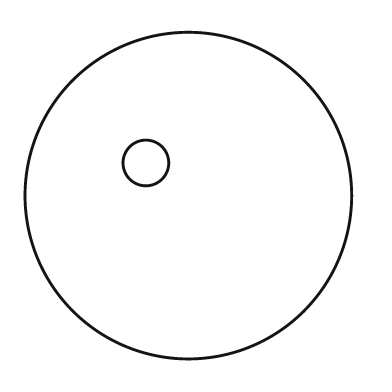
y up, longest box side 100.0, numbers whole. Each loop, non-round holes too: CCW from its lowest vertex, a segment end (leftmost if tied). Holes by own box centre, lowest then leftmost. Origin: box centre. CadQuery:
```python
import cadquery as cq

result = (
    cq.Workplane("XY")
    .moveTo(0.0, 0.0)
    .circle(50.0)
    .moveTo(-13.0, 10.0)
    .circle(7.0)
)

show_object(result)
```